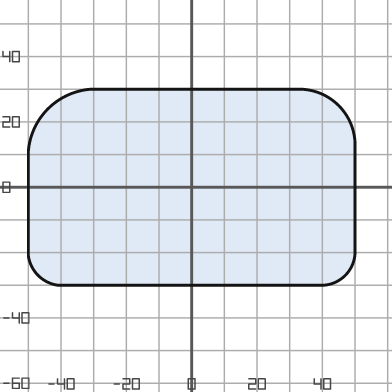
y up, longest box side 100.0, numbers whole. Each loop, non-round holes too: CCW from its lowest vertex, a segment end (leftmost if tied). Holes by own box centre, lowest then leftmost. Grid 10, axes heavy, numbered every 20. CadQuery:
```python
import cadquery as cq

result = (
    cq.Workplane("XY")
    .moveTo(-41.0, -30.0)
    .lineTo(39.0, -30.0)
    .threePointArc((47.0, -27.0), (50.0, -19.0))
    .lineTo(50.0, 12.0)
    .threePointArc((45.0, 25.0), (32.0, 30.0))
    .lineTo(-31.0, 30.0)
    .threePointArc((-44.0, 24.0), (-50.0, 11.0))
    .lineTo(-50.0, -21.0)
    .threePointArc((-47.0, -27.0), (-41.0, -30.0))
    .close()
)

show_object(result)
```